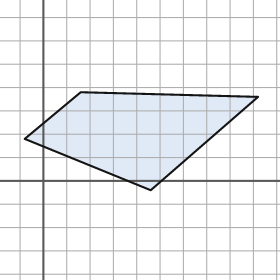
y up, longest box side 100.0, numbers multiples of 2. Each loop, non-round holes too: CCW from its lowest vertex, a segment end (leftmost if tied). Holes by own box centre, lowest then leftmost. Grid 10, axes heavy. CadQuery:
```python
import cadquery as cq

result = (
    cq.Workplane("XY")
    .moveTo(46.0, -4.0)
    .lineTo(92.0, 36.0)
    .lineTo(16.0, 38.0)
    .lineTo(-8.0, 18.0)
    .close()
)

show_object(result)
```